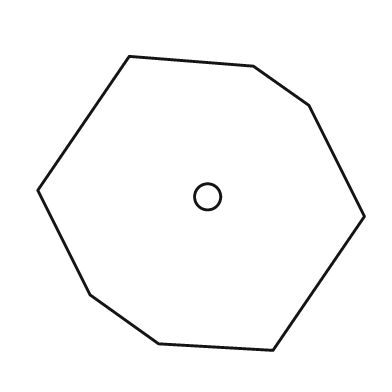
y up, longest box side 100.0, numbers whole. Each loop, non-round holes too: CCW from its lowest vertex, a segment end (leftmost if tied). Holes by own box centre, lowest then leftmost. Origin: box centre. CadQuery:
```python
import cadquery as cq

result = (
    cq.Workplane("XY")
    .moveTo(22.0, -45.0)
    .lineTo(50.0, -4.0)
    .lineTo(33.0, 30.0)
    .lineTo(16.0, 42.0)
    .lineTo(-22.0, 45.0)
    .lineTo(-50.0, 4.0)
    .lineTo(-34.0, -28.0)
    .lineTo(-13.0, -43.0)
    .close()
    .moveTo(2.0, 2.0)
    .circle(4.0)
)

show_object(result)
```